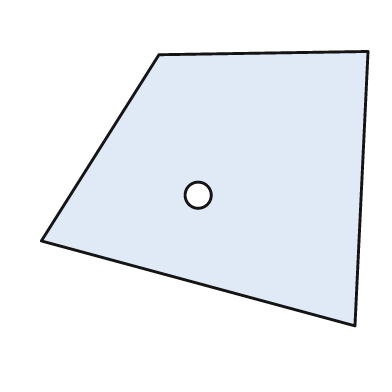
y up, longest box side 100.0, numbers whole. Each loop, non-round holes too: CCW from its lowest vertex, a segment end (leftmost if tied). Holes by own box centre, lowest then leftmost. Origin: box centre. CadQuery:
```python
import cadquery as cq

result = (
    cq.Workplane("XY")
    .moveTo(46.0, -42.0)
    .lineTo(50.0, 42.0)
    .lineTo(-14.0, 41.0)
    .lineTo(-50.0, -16.0)
    .close()
    .moveTo(-2.0, -2.0)
    .circle(4.0)
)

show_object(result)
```